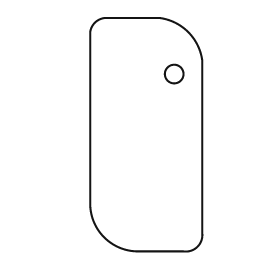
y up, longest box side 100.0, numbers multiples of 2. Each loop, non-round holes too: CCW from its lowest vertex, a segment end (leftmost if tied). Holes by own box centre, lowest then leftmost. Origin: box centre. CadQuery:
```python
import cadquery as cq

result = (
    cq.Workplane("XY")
    .moveTo(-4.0, -50.0)
    .lineTo(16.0, -50.0)
    .threePointArc((22.0, -48.0), (24.0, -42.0))
    .lineTo(24.0, 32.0)
    .threePointArc((18.0, 44.0), (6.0, 50.0))
    .lineTo(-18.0, 50.0)
    .threePointArc((-22.0, 48.0), (-24.0, 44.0))
    .lineTo(-24.0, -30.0)
    .threePointArc((-18.0, -44.0), (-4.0, -50.0))
    .close()
    .moveTo(12.0, 26.0)
    .circle(4.0)
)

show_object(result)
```